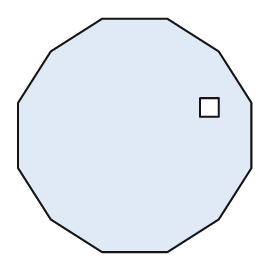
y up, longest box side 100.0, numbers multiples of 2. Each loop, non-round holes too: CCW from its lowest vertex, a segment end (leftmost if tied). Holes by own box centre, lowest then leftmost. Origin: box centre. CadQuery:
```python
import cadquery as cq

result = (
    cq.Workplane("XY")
    .moveTo(-14.0, -50.0)
    .lineTo(14.0, -50.0)
    .lineTo(36.0, -36.0)
    .lineTo(50.0, -14.0)
    .lineTo(50.0, 14.0)
    .lineTo(36.0, 36.0)
    .lineTo(14.0, 50.0)
    .lineTo(-14.0, 50.0)
    .lineTo(-36.0, 36.0)
    .lineTo(-50.0, 14.0)
    .lineTo(-50.0, -14.0)
    .lineTo(-36.0, -36.0)
    .close()
    .moveTo(28.0, 8.0)
    .lineTo(36.0, 8.0)
    .lineTo(36.0, 16.0)
    .lineTo(28.0, 16.0)
    .close()
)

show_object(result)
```